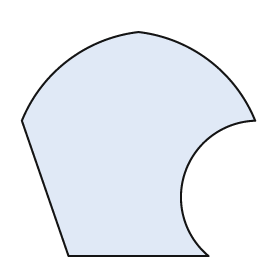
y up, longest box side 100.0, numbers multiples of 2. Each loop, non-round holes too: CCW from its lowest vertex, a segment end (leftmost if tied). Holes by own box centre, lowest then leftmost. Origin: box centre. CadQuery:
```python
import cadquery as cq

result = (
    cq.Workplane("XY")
    .moveTo(-30.0, -48.0)
    .lineTo(30.0, -48.0)
    .threePointArc((20.0, -12.0), (50.0, 10.0))
    .threePointArc((30.0, 36.0), (0.0, 48.0))
    .threePointArc((-30.0, 36.0), (-50.0, 10.0))
    .close()
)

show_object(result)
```